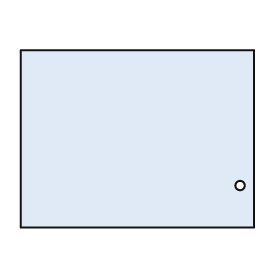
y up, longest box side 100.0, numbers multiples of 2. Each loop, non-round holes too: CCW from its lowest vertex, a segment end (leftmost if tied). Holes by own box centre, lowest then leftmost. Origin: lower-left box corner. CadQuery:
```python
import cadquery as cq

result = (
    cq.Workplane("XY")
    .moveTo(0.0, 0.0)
    .lineTo(100.0, 0.0)
    .lineTo(100.0, 76.0)
    .lineTo(0.0, 76.0)
    .close()
    .moveTo(94.0, 18.0)
    .circle(2.0)
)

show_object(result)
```